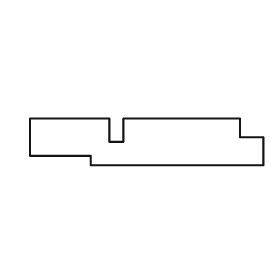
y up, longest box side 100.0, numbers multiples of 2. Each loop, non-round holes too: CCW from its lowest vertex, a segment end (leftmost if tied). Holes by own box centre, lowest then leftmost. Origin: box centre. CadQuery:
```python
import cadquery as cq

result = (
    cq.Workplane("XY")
    .moveTo(-24.0, -10.0)
    .lineTo(50.0, -10.0)
    .lineTo(50.0, 2.0)
    .lineTo(40.0, 2.0)
    .lineTo(40.0, 10.0)
    .lineTo(-10.0, 10.0)
    .lineTo(-10.0, 0.0)
    .lineTo(-16.0, 0.0)
    .lineTo(-16.0, 10.0)
    .lineTo(-50.0, 10.0)
    .lineTo(-50.0, -6.0)
    .lineTo(-24.0, -6.0)
    .close()
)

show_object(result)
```